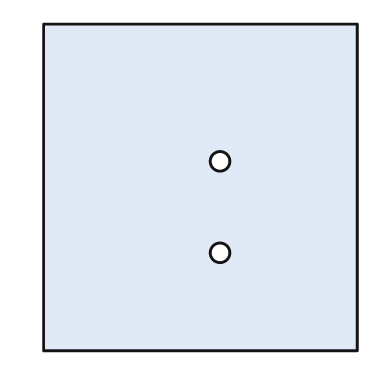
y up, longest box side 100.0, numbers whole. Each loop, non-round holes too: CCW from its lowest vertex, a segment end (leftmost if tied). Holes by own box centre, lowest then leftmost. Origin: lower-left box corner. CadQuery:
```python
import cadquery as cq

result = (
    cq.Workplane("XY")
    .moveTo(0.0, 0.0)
    .lineTo(96.0, 0.0)
    .lineTo(96.0, 100.0)
    .lineTo(0.0, 100.0)
    .close()
    .moveTo(54.0, 30.0)
    .circle(3.0)
    .moveTo(54.0, 58.0)
    .circle(3.0)
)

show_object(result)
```